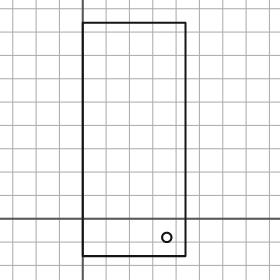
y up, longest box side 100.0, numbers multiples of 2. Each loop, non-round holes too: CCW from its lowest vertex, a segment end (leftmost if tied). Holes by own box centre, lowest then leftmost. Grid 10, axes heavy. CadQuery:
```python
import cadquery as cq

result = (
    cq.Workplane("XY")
    .moveTo(0.0, -16.0)
    .lineTo(44.0, -16.0)
    .lineTo(44.0, 84.0)
    .lineTo(0.0, 84.0)
    .close()
    .moveTo(36.0, -8.0)
    .circle(2.0)
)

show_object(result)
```